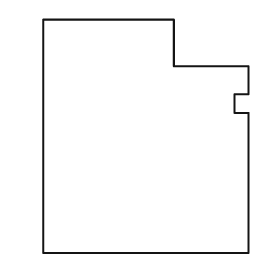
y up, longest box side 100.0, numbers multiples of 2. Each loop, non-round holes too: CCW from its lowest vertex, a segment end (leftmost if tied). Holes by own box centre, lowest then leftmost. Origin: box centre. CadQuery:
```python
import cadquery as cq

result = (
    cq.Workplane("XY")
    .moveTo(-44.0, -50.0)
    .lineTo(44.0, -50.0)
    .lineTo(44.0, 10.0)
    .lineTo(38.0, 10.0)
    .lineTo(38.0, 18.0)
    .lineTo(44.0, 18.0)
    .lineTo(44.0, 30.0)
    .lineTo(12.0, 30.0)
    .lineTo(12.0, 50.0)
    .lineTo(-44.0, 50.0)
    .close()
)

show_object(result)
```